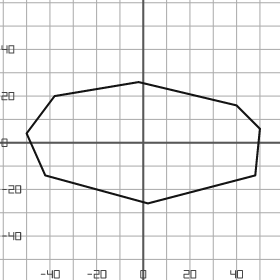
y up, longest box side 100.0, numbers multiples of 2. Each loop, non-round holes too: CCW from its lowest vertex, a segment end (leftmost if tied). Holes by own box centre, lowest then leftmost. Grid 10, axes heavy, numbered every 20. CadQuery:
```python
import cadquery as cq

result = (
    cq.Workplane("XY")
    .moveTo(2.0, -26.0)
    .lineTo(48.0, -14.0)
    .lineTo(50.0, 6.0)
    .lineTo(40.0, 16.0)
    .lineTo(-2.0, 26.0)
    .lineTo(-38.0, 20.0)
    .lineTo(-50.0, 4.0)
    .lineTo(-42.0, -14.0)
    .close()
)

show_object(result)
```